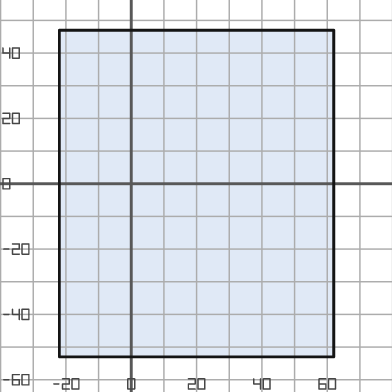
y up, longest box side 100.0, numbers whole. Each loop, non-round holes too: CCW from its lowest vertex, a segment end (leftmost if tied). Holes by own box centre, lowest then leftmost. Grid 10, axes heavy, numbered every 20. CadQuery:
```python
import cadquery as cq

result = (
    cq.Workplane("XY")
    .moveTo(-22.0, -53.0)
    .lineTo(62.0, -53.0)
    .lineTo(62.0, 47.0)
    .lineTo(-22.0, 47.0)
    .close()
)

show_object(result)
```